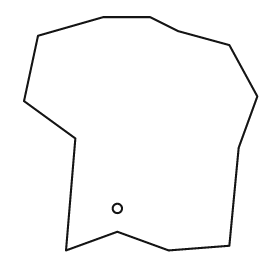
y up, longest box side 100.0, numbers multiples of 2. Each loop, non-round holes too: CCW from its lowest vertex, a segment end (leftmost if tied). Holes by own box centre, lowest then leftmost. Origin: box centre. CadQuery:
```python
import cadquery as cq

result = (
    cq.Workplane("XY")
    .moveTo(-32.0, -50.0)
    .lineTo(-10.0, -42.0)
    .lineTo(12.0, -50.0)
    .lineTo(38.0, -48.0)
    .lineTo(42.0, -6.0)
    .lineTo(50.0, 16.0)
    .lineTo(38.0, 38.0)
    .lineTo(16.0, 44.0)
    .lineTo(4.0, 50.0)
    .lineTo(-16.0, 50.0)
    .lineTo(-44.0, 42.0)
    .lineTo(-50.0, 14.0)
    .lineTo(-28.0, -2.0)
    .close()
    .moveTo(-10.0, -32.0)
    .circle(2.0)
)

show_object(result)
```